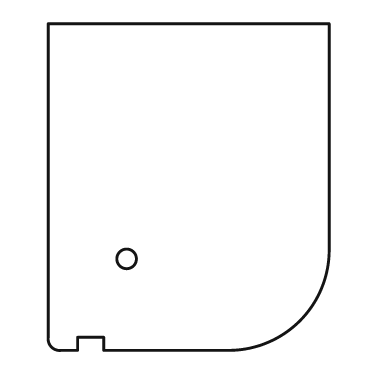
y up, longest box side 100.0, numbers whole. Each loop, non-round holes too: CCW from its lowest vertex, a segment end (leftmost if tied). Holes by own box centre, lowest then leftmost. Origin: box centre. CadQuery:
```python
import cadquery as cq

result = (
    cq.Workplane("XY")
    .moveTo(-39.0, -50.0)
    .lineTo(-34.0, -50.0)
    .lineTo(-34.0, -46.0)
    .lineTo(-26.0, -46.0)
    .lineTo(-26.0, -50.0)
    .lineTo(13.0, -50.0)
    .threePointArc((34.0, -41.0), (43.0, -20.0))
    .lineTo(43.0, 50.0)
    .lineTo(-43.0, 50.0)
    .lineTo(-43.0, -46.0)
    .threePointArc((-42.0, -49.0), (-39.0, -50.0))
    .close()
    .moveTo(-19.0, -22.0)
    .circle(3.0)
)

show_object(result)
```